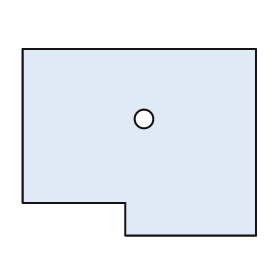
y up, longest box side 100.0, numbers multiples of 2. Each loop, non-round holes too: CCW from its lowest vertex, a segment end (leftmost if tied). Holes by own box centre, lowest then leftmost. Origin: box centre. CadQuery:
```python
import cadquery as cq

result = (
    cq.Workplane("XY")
    .moveTo(-6.0, -40.0)
    .lineTo(50.0, -40.0)
    .lineTo(50.0, 40.0)
    .lineTo(-50.0, 40.0)
    .lineTo(-50.0, -26.0)
    .lineTo(-6.0, -26.0)
    .close()
    .moveTo(2.0, 10.0)
    .circle(4.0)
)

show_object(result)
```